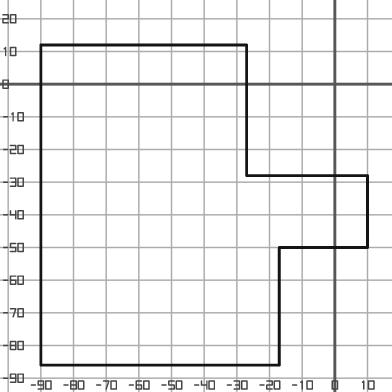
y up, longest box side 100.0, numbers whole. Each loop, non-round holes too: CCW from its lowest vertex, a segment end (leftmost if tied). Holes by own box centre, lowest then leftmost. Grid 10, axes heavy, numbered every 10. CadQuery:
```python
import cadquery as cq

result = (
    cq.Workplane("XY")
    .moveTo(-90.0, -86.0)
    .lineTo(-17.0, -86.0)
    .lineTo(-17.0, -50.0)
    .lineTo(10.0, -50.0)
    .lineTo(10.0, -28.0)
    .lineTo(-27.0, -28.0)
    .lineTo(-27.0, 12.0)
    .lineTo(-90.0, 12.0)
    .close()
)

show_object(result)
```